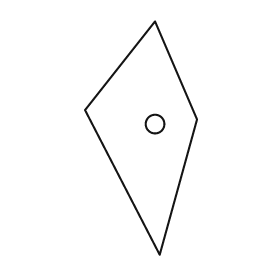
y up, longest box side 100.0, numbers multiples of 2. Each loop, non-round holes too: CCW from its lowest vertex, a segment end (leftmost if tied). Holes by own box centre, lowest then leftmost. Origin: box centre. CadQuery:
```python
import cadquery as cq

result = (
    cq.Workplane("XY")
    .moveTo(8.0, -50.0)
    .lineTo(24.0, 8.0)
    .lineTo(6.0, 50.0)
    .lineTo(-24.0, 12.0)
    .close()
    .moveTo(6.0, 6.0)
    .circle(4.0)
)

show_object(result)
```